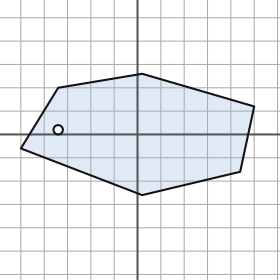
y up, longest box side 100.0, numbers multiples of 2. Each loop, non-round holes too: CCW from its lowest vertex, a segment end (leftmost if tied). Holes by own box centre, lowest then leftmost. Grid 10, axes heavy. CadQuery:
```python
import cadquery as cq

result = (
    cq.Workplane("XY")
    .moveTo(2.0, -26.0)
    .lineTo(44.0, -16.0)
    .lineTo(50.0, 12.0)
    .lineTo(2.0, 26.0)
    .lineTo(-34.0, 20.0)
    .lineTo(-50.0, -6.0)
    .close()
    .moveTo(-34.0, 2.0)
    .circle(2.0)
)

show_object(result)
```